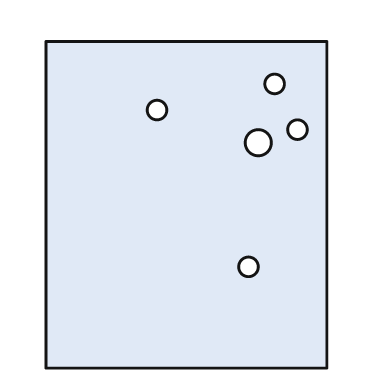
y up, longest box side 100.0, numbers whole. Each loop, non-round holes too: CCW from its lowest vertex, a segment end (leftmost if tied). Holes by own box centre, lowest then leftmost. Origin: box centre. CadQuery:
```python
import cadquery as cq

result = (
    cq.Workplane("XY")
    .moveTo(-43.0, -50.0)
    .lineTo(43.0, -50.0)
    .lineTo(43.0, 50.0)
    .lineTo(-43.0, 50.0)
    .close()
    .moveTo(19.0, -19.0)
    .circle(3.0)
    .moveTo(22.0, 19.0)
    .circle(4.0)
    .moveTo(34.0, 23.0)
    .circle(3.0)
    .moveTo(-9.0, 29.0)
    .circle(3.0)
    .moveTo(27.0, 37.0)
    .circle(3.0)
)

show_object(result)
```